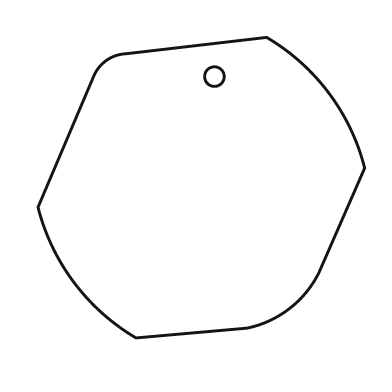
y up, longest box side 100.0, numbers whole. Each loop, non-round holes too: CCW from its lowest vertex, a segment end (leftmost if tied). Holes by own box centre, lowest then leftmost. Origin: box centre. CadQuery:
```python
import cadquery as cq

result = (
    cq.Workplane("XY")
    .moveTo(-20.0, -46.0)
    .lineTo(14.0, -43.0)
    .threePointArc((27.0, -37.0), (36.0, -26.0))
    .lineTo(50.0, 6.0)
    .threePointArc((39.0, 29.0), (20.0, 46.0))
    .lineTo(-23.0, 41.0)
    .threePointArc((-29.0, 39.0), (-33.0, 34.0))
    .lineTo(-50.0, -6.0)
    .threePointArc((-39.0, -29.0), (-20.0, -46.0))
    .close()
    .moveTo(4.0, 34.0)
    .circle(3.0)
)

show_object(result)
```